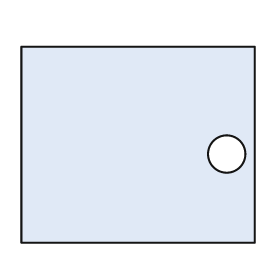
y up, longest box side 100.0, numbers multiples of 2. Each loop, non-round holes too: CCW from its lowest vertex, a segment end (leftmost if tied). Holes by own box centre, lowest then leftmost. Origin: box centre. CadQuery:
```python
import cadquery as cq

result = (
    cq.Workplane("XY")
    .moveTo(-50.0, -42.0)
    .lineTo(50.0, -42.0)
    .lineTo(50.0, 42.0)
    .lineTo(-50.0, 42.0)
    .close()
    .moveTo(38.0, -4.0)
    .circle(8.0)
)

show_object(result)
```